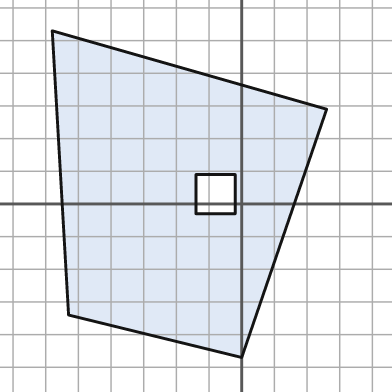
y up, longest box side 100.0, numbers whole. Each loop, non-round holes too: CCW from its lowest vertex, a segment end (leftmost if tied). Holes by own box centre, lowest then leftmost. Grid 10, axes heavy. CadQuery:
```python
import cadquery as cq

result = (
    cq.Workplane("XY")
    .moveTo(0.0, -47.0)
    .lineTo(26.0, 29.0)
    .lineTo(-58.0, 53.0)
    .lineTo(-53.0, -34.0)
    .close()
    .moveTo(-14.0, -3.0)
    .lineTo(-2.0, -3.0)
    .lineTo(-2.0, 9.0)
    .lineTo(-14.0, 9.0)
    .close()
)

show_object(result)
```